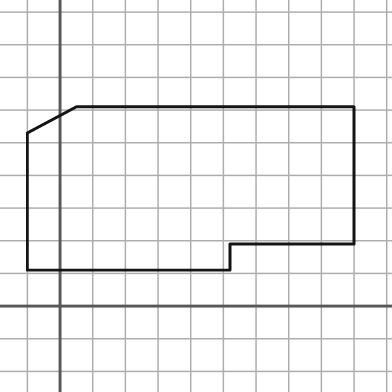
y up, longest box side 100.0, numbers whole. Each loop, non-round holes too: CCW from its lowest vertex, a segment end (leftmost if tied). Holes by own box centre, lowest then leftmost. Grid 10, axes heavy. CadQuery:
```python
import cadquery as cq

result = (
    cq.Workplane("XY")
    .moveTo(-10.0, 11.0)
    .lineTo(52.0, 11.0)
    .lineTo(52.0, 19.0)
    .lineTo(90.0, 19.0)
    .lineTo(90.0, 61.0)
    .lineTo(5.0, 61.0)
    .lineTo(-10.0, 53.0)
    .close()
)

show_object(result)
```